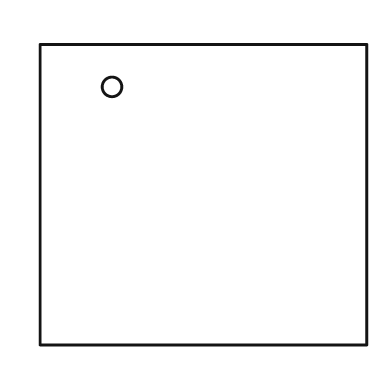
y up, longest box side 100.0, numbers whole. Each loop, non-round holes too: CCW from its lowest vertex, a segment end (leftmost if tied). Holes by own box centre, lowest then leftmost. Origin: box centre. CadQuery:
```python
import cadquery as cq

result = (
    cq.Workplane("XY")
    .moveTo(-50.0, -46.0)
    .lineTo(50.0, -46.0)
    .lineTo(50.0, 46.0)
    .lineTo(-50.0, 46.0)
    .close()
    .moveTo(-28.0, 33.0)
    .circle(3.0)
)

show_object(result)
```